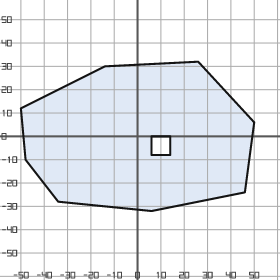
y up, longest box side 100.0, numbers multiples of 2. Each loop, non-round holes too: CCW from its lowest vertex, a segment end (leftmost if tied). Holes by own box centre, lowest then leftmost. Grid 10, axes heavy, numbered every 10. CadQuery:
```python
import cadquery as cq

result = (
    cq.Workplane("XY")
    .moveTo(6.0, -32.0)
    .lineTo(46.0, -24.0)
    .lineTo(50.0, 6.0)
    .lineTo(26.0, 32.0)
    .lineTo(-14.0, 30.0)
    .lineTo(-50.0, 12.0)
    .lineTo(-48.0, -10.0)
    .lineTo(-34.0, -28.0)
    .close()
    .moveTo(6.0, -8.0)
    .lineTo(14.0, -8.0)
    .lineTo(14.0, 0.0)
    .lineTo(6.0, 0.0)
    .close()
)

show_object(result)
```